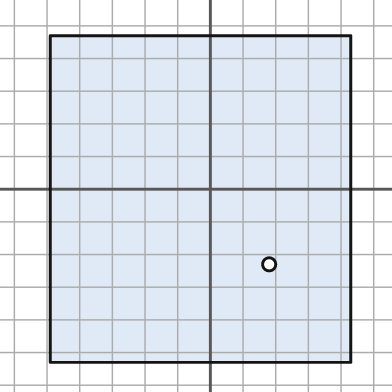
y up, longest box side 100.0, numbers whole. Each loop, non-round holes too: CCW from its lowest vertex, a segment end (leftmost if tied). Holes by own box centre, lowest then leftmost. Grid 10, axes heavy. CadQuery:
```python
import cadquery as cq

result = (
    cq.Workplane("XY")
    .moveTo(-49.0, -53.0)
    .lineTo(43.0, -53.0)
    .lineTo(43.0, 47.0)
    .lineTo(-49.0, 47.0)
    .close()
    .moveTo(18.0, -23.0)
    .circle(2.0)
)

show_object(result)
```